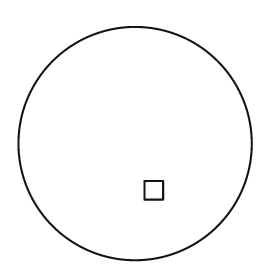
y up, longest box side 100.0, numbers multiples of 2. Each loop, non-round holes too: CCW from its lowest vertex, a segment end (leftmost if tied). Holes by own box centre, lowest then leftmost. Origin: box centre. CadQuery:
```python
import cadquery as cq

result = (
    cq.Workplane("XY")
    .moveTo(0.0, 0.0)
    .circle(50.0)
    .moveTo(4.0, -24.0)
    .lineTo(12.0, -24.0)
    .lineTo(12.0, -16.0)
    .lineTo(4.0, -16.0)
    .close()
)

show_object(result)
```